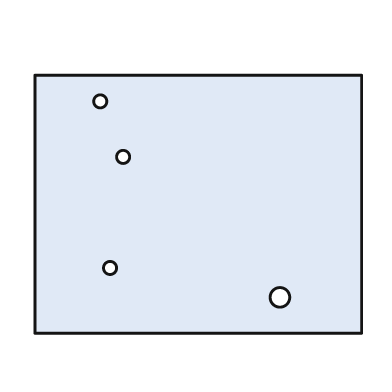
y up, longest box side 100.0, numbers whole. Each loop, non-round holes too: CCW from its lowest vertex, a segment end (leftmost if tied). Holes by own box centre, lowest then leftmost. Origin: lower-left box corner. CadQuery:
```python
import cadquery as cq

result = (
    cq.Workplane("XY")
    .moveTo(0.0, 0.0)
    .lineTo(100.0, 0.0)
    .lineTo(100.0, 79.0)
    .lineTo(0.0, 79.0)
    .close()
    .moveTo(75.0, 11.0)
    .circle(3.0)
    .moveTo(23.0, 20.0)
    .circle(2.0)
    .moveTo(27.0, 54.0)
    .circle(2.0)
    .moveTo(20.0, 71.0)
    .circle(2.0)
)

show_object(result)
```